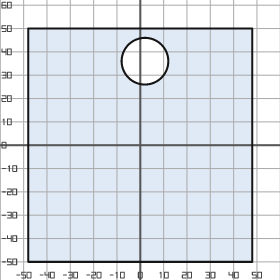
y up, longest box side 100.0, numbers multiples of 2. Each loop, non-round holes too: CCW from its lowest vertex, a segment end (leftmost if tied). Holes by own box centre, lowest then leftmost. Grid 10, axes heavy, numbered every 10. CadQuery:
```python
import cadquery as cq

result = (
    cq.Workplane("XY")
    .moveTo(-48.0, -50.0)
    .lineTo(48.0, -50.0)
    .lineTo(48.0, 50.0)
    .lineTo(-48.0, 50.0)
    .close()
    .moveTo(2.0, 36.0)
    .circle(10.0)
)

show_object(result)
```